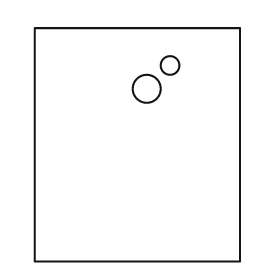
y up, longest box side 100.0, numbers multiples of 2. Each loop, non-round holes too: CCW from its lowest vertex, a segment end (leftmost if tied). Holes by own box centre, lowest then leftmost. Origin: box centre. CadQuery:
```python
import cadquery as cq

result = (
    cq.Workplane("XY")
    .moveTo(-44.0, -50.0)
    .lineTo(44.0, -50.0)
    .lineTo(44.0, 50.0)
    .lineTo(-44.0, 50.0)
    .close()
    .moveTo(4.0, 24.0)
    .circle(6.0)
    .moveTo(14.0, 34.0)
    .circle(4.0)
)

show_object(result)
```